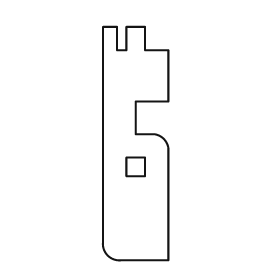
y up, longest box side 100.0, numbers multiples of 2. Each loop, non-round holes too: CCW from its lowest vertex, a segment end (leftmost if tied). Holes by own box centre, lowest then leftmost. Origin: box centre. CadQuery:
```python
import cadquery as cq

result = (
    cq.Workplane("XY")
    .moveTo(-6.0, -50.0)
    .lineTo(14.0, -50.0)
    .lineTo(14.0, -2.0)
    .threePointArc((12.0, 2.0), (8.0, 4.0))
    .lineTo(0.0, 4.0)
    .lineTo(0.0, 18.0)
    .lineTo(14.0, 18.0)
    .lineTo(14.0, 40.0)
    .lineTo(4.0, 40.0)
    .lineTo(4.0, 50.0)
    .lineTo(-4.0, 50.0)
    .lineTo(-4.0, 40.0)
    .lineTo(-8.0, 40.0)
    .lineTo(-8.0, 50.0)
    .lineTo(-14.0, 50.0)
    .lineTo(-14.0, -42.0)
    .threePointArc((-12.0, -48.0), (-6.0, -50.0))
    .close()
    .moveTo(-4.0, -14.0)
    .lineTo(4.0, -14.0)
    .lineTo(4.0, -6.0)
    .lineTo(-4.0, -6.0)
    .close()
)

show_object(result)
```